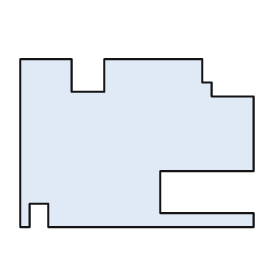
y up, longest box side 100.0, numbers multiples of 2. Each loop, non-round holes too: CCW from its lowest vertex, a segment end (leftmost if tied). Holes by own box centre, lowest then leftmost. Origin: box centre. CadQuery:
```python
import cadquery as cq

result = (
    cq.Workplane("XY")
    .moveTo(-50.0, -36.0)
    .lineTo(-46.0, -36.0)
    .lineTo(-46.0, -26.0)
    .lineTo(-38.0, -26.0)
    .lineTo(-38.0, -36.0)
    .lineTo(50.0, -36.0)
    .lineTo(50.0, -30.0)
    .lineTo(10.0, -30.0)
    .lineTo(10.0, -12.0)
    .lineTo(50.0, -12.0)
    .lineTo(50.0, 20.0)
    .lineTo(32.0, 20.0)
    .lineTo(32.0, 26.0)
    .lineTo(28.0, 26.0)
    .lineTo(28.0, 36.0)
    .lineTo(-14.0, 36.0)
    .lineTo(-14.0, 22.0)
    .lineTo(-28.0, 22.0)
    .lineTo(-28.0, 36.0)
    .lineTo(-50.0, 36.0)
    .close()
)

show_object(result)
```